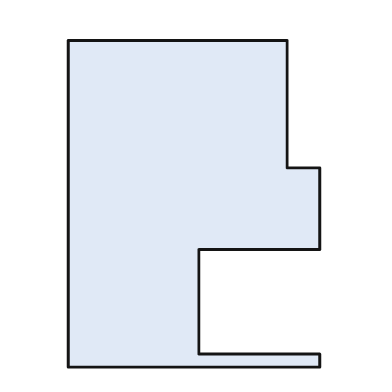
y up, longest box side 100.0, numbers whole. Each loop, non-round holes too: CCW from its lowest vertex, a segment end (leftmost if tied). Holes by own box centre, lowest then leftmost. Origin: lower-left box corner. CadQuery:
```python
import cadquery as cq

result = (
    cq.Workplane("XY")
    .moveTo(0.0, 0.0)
    .lineTo(77.0, 0.0)
    .lineTo(77.0, 4.0)
    .lineTo(40.0, 4.0)
    .lineTo(40.0, 36.0)
    .lineTo(77.0, 36.0)
    .lineTo(77.0, 61.0)
    .lineTo(67.0, 61.0)
    .lineTo(67.0, 100.0)
    .lineTo(0.0, 100.0)
    .close()
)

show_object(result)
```